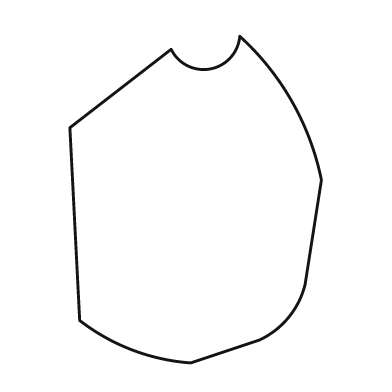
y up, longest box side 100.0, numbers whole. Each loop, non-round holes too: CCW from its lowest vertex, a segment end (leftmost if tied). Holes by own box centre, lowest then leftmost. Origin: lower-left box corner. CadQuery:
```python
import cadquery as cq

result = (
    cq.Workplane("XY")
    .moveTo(37.0, 0.0)
    .lineTo(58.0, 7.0)
    .threePointArc((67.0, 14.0), (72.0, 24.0))
    .lineTo(77.0, 56.0)
    .threePointArc((68.0, 80.0), (52.0, 100.0))
    .threePointArc((43.0, 90.0), (31.0, 96.0))
    .lineTo(0.0, 72.0)
    .lineTo(3.0, 13.0)
    .threePointArc((19.0, 4.0), (37.0, 0.0))
    .close()
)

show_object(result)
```